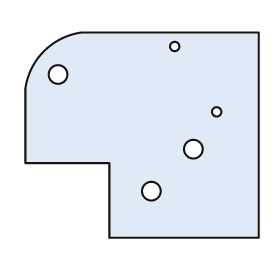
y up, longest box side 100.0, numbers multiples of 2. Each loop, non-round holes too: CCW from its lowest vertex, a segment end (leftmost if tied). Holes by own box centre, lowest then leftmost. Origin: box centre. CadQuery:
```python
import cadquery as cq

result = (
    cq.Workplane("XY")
    .moveTo(-14.0, -44.0)
    .lineTo(50.0, -44.0)
    .lineTo(50.0, 44.0)
    .lineTo(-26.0, 44.0)
    .threePointArc((-42.0, 36.0), (-50.0, 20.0))
    .lineTo(-50.0, -12.0)
    .lineTo(-14.0, -12.0)
    .close()
    .moveTo(4.0, -24.0)
    .circle(4.0)
    .moveTo(22.0, -6.0)
    .circle(4.0)
    .moveTo(32.0, 10.0)
    .circle(2.0)
    .moveTo(-36.0, 26.0)
    .circle(4.0)
    .moveTo(14.0, 38.0)
    .circle(2.0)
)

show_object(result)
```